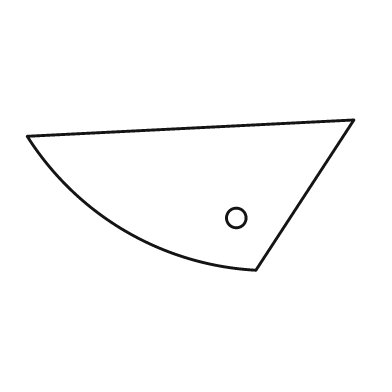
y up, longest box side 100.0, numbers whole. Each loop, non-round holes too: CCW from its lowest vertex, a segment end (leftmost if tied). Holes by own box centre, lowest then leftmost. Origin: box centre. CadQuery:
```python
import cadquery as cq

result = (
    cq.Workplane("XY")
    .moveTo(20.0, -23.0)
    .lineTo(50.0, 23.0)
    .lineTo(-50.0, 18.0)
    .threePointArc((-20.0, -11.0), (20.0, -23.0))
    .close()
    .moveTo(14.0, -7.0)
    .circle(3.0)
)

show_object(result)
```